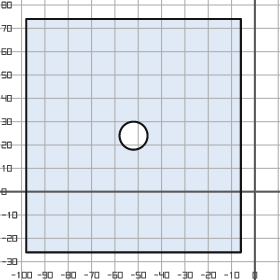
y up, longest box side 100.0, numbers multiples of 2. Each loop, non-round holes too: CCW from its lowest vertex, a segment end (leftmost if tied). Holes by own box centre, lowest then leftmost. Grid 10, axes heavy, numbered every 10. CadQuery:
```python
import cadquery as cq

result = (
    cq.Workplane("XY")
    .moveTo(-98.0, -26.0)
    .lineTo(-6.0, -26.0)
    .lineTo(-6.0, 74.0)
    .lineTo(-98.0, 74.0)
    .close()
    .moveTo(-52.0, 24.0)
    .circle(6.0)
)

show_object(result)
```